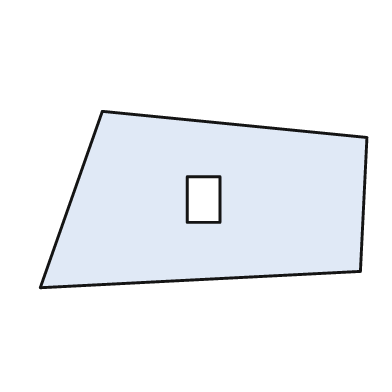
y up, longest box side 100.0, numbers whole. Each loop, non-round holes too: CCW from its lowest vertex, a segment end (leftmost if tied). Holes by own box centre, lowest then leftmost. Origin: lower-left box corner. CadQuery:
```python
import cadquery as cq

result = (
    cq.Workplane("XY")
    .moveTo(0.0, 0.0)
    .lineTo(98.0, 5.0)
    .lineTo(100.0, 46.0)
    .lineTo(19.0, 54.0)
    .close()
    .moveTo(45.0, 20.0)
    .lineTo(55.0, 20.0)
    .lineTo(55.0, 34.0)
    .lineTo(45.0, 34.0)
    .close()
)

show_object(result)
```